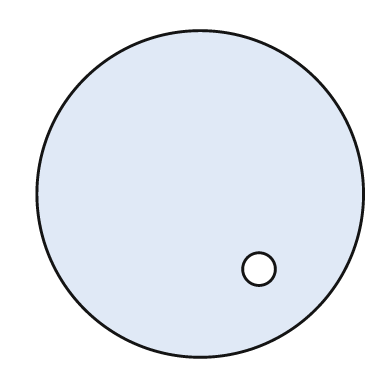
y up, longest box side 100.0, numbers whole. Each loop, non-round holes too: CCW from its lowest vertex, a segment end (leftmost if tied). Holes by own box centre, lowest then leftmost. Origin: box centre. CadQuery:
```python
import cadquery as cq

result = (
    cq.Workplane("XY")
    .moveTo(0.0, 0.0)
    .circle(50.0)
    .moveTo(18.0, -23.0)
    .circle(5.0)
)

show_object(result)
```